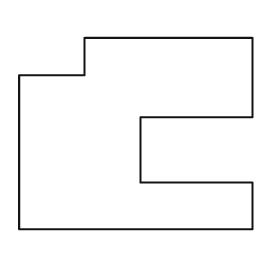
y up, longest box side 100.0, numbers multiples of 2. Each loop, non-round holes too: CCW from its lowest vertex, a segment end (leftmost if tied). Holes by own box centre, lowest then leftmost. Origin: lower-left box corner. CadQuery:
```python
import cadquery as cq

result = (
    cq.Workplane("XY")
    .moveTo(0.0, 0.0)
    .lineTo(100.0, 0.0)
    .lineTo(100.0, 20.0)
    .lineTo(52.0, 20.0)
    .lineTo(52.0, 48.0)
    .lineTo(100.0, 48.0)
    .lineTo(100.0, 82.0)
    .lineTo(28.0, 82.0)
    .lineTo(28.0, 66.0)
    .lineTo(0.0, 66.0)
    .close()
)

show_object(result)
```